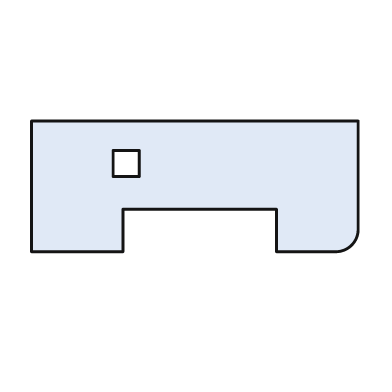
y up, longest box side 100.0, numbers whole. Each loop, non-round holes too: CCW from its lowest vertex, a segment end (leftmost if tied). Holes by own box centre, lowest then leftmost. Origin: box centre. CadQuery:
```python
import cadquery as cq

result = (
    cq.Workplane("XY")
    .moveTo(-50.0, -20.0)
    .lineTo(-22.0, -20.0)
    .lineTo(-22.0, -7.0)
    .lineTo(25.0, -7.0)
    .lineTo(25.0, -20.0)
    .lineTo(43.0, -20.0)
    .threePointArc((48.0, -18.0), (50.0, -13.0))
    .lineTo(50.0, 20.0)
    .lineTo(-50.0, 20.0)
    .close()
    .moveTo(-25.0, 3.0)
    .lineTo(-17.0, 3.0)
    .lineTo(-17.0, 11.0)
    .lineTo(-25.0, 11.0)
    .close()
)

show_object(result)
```